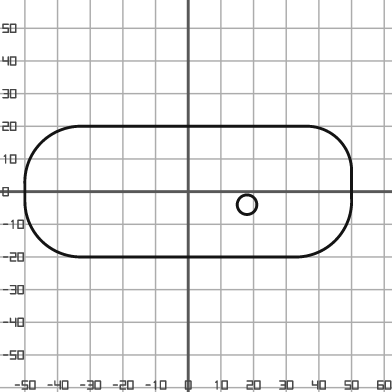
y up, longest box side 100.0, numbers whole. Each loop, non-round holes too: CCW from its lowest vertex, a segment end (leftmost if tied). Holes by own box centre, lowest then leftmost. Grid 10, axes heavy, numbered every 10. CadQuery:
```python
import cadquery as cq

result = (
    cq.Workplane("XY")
    .moveTo(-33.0, -20.0)
    .lineTo(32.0, -20.0)
    .threePointArc((45.0, -15.0), (50.0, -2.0))
    .lineTo(50.0, 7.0)
    .threePointArc((46.0, 16.0), (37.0, 20.0))
    .lineTo(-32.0, 20.0)
    .threePointArc((-45.0, 15.0), (-50.0, 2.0))
    .lineTo(-50.0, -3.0)
    .threePointArc((-45.0, -15.0), (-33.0, -20.0))
    .close()
    .moveTo(18.0, -4.0)
    .circle(3.0)
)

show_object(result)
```